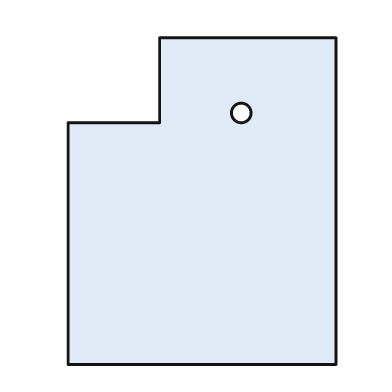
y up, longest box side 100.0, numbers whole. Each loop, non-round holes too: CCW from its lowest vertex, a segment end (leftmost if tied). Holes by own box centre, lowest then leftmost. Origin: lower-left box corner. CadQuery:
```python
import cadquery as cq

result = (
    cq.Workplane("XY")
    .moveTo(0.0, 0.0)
    .lineTo(82.0, 0.0)
    .lineTo(82.0, 100.0)
    .lineTo(28.0, 100.0)
    .lineTo(28.0, 74.0)
    .lineTo(0.0, 74.0)
    .close()
    .moveTo(53.0, 77.0)
    .circle(3.0)
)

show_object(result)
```